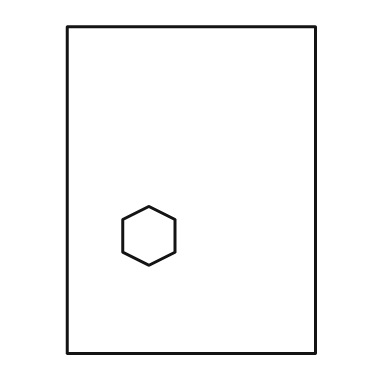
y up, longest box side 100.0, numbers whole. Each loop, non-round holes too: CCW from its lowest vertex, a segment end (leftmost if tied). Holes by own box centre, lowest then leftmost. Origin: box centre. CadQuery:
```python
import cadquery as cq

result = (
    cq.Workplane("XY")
    .moveTo(-38.0, -50.0)
    .lineTo(38.0, -50.0)
    .lineTo(38.0, 50.0)
    .lineTo(-38.0, 50.0)
    .close()
    .moveTo(-13.0, -23.0)
    .lineTo(-5.0, -19.0)
    .lineTo(-5.0, -9.0)
    .lineTo(-13.0, -5.0)
    .lineTo(-21.0, -9.0)
    .lineTo(-21.0, -19.0)
    .close()
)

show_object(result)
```